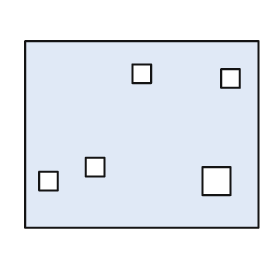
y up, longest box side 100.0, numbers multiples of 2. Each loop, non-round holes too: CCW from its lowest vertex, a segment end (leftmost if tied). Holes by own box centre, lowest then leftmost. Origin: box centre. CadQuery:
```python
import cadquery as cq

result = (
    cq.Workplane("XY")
    .moveTo(-50.0, -40.0)
    .lineTo(50.0, -40.0)
    .lineTo(50.0, 40.0)
    .lineTo(-50.0, 40.0)
    .close()
    .moveTo(-44.0, -24.0)
    .lineTo(-36.0, -24.0)
    .lineTo(-36.0, -16.0)
    .lineTo(-44.0, -16.0)
    .close()
    .moveTo(26.0, -26.0)
    .lineTo(38.0, -26.0)
    .lineTo(38.0, -14.0)
    .lineTo(26.0, -14.0)
    .close()
    .moveTo(-24.0, -18.0)
    .lineTo(-16.0, -18.0)
    .lineTo(-16.0, -10.0)
    .lineTo(-24.0, -10.0)
    .close()
    .moveTo(34.0, 20.0)
    .lineTo(42.0, 20.0)
    .lineTo(42.0, 28.0)
    .lineTo(34.0, 28.0)
    .close()
    .moveTo(-4.0, 22.0)
    .lineTo(4.0, 22.0)
    .lineTo(4.0, 30.0)
    .lineTo(-4.0, 30.0)
    .close()
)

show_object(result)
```